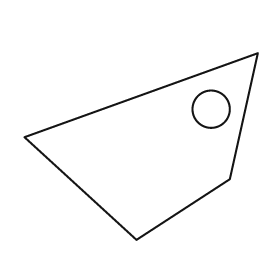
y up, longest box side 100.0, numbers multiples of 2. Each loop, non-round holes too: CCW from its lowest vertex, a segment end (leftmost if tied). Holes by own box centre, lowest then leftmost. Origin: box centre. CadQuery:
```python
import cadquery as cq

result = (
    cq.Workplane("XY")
    .moveTo(-2.0, -40.0)
    .lineTo(38.0, -14.0)
    .lineTo(50.0, 40.0)
    .lineTo(-50.0, 4.0)
    .close()
    .moveTo(30.0, 16.0)
    .circle(8.0)
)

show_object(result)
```